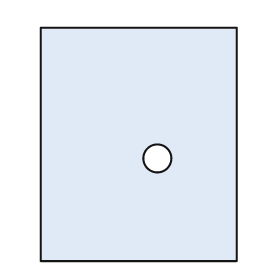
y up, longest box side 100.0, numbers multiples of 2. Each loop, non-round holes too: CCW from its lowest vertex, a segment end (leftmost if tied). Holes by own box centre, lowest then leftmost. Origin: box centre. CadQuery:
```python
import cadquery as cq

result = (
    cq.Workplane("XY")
    .moveTo(-42.0, -50.0)
    .lineTo(42.0, -50.0)
    .lineTo(42.0, 50.0)
    .lineTo(-42.0, 50.0)
    .close()
    .moveTo(8.0, -6.0)
    .circle(6.0)
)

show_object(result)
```